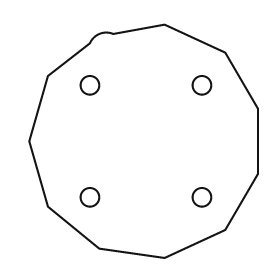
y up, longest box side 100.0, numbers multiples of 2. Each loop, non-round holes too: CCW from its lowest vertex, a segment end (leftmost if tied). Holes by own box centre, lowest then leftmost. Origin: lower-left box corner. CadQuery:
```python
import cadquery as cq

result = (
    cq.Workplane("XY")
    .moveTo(58.0, 0.0)
    .lineTo(84.0, 12.0)
    .lineTo(98.0, 36.0)
    .lineTo(98.0, 64.0)
    .lineTo(84.0, 88.0)
    .lineTo(58.0, 100.0)
    .lineTo(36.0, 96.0)
    .threePointArc((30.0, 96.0), (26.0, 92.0))
    .lineTo(8.0, 78.0)
    .lineTo(0.0, 50.0)
    .lineTo(8.0, 22.0)
    .lineTo(30.0, 4.0)
    .close()
    .moveTo(26.0, 26.0)
    .circle(4.0)
    .moveTo(74.0, 26.0)
    .circle(4.0)
    .moveTo(26.0, 74.0)
    .circle(4.0)
    .moveTo(74.0, 74.0)
    .circle(4.0)
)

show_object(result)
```